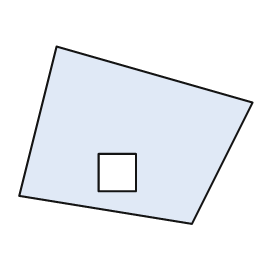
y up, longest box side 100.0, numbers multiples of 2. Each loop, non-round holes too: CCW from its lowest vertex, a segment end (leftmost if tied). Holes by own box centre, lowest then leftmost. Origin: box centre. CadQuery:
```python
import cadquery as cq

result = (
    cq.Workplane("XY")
    .moveTo(24.0, -38.0)
    .lineTo(50.0, 14.0)
    .lineTo(-34.0, 38.0)
    .lineTo(-50.0, -26.0)
    .close()
    .moveTo(-16.0, -24.0)
    .lineTo(0.0, -24.0)
    .lineTo(0.0, -8.0)
    .lineTo(-16.0, -8.0)
    .close()
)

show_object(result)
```